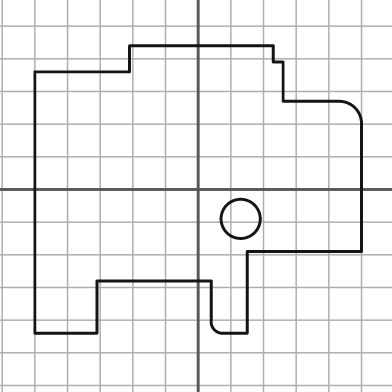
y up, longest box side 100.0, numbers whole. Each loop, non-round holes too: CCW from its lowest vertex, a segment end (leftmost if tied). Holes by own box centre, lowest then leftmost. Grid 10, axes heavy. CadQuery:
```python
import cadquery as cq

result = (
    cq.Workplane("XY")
    .moveTo(-50.0, -44.0)
    .lineTo(-31.0, -44.0)
    .lineTo(-31.0, -28.0)
    .lineTo(4.0, -28.0)
    .lineTo(4.0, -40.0)
    .threePointArc((5.0, -43.0), (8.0, -44.0))
    .lineTo(15.0, -44.0)
    .lineTo(15.0, -19.0)
    .lineTo(50.0, -19.0)
    .lineTo(50.0, 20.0)
    .threePointArc((48.0, 25.0), (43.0, 27.0))
    .lineTo(26.0, 27.0)
    .lineTo(26.0, 39.0)
    .lineTo(23.0, 39.0)
    .lineTo(23.0, 44.0)
    .lineTo(-21.0, 44.0)
    .lineTo(-21.0, 36.0)
    .lineTo(-50.0, 36.0)
    .close()
    .moveTo(13.0, -9.0)
    .circle(6.0)
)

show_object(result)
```